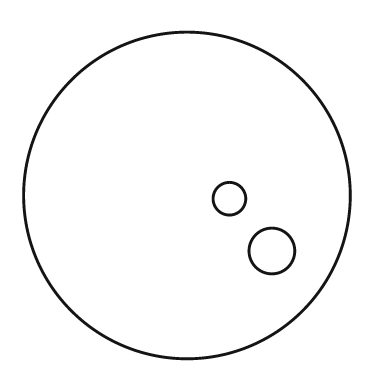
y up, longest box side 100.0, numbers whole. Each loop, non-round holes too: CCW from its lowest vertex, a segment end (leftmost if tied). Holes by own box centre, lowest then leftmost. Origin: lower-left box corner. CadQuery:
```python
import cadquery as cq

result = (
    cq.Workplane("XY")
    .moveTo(50.0, 50.0)
    .circle(50.0)
    .moveTo(76.0, 33.0)
    .circle(7.0)
    .moveTo(63.0, 49.0)
    .circle(5.0)
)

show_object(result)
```